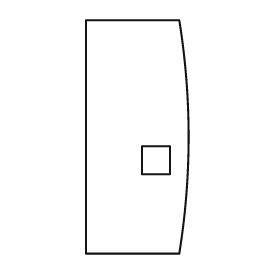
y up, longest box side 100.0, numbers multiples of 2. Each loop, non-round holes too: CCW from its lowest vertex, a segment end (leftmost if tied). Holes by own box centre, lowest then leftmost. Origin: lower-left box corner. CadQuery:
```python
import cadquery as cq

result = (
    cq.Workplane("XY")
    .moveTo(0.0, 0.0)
    .lineTo(40.0, 0.0)
    .threePointArc((44.0, 50.0), (40.0, 100.0))
    .lineTo(0.0, 100.0)
    .close()
    .moveTo(24.0, 34.0)
    .lineTo(36.0, 34.0)
    .lineTo(36.0, 46.0)
    .lineTo(24.0, 46.0)
    .close()
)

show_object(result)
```